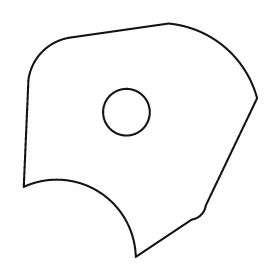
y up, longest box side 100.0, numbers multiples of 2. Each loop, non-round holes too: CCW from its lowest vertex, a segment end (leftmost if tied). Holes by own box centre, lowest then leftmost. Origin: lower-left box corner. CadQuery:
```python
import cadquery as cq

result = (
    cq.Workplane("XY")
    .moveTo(48.0, 0.0)
    .lineTo(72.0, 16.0)
    .threePointArc((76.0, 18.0), (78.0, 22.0))
    .lineTo(100.0, 68.0)
    .threePointArc((86.0, 90.0), (62.0, 100.0))
    .lineTo(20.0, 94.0)
    .threePointArc((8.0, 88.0), (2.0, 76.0))
    .lineTo(0.0, 30.0)
    .threePointArc((32.0, 28.0), (48.0, 0.0))
    .close()
    .moveTo(44.0, 62.0)
    .circle(10.0)
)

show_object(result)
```